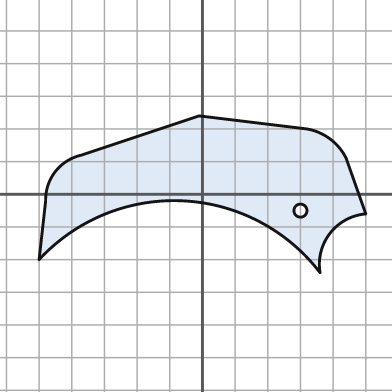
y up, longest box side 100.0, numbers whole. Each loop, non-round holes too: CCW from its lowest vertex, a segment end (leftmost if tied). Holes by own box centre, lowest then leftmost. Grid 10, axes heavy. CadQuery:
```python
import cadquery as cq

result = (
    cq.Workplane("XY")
    .moveTo(36.0, -24.0)
    .threePointArc((39.0, -12.0), (50.0, -6.0))
    .lineTo(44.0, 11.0)
    .threePointArc((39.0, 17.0), (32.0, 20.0))
    .lineTo(-1.0, 24.0)
    .lineTo(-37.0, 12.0)
    .threePointArc((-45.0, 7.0), (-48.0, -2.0))
    .lineTo(-50.0, -20.0)
    .threePointArc((-6.0, -2.0), (36.0, -24.0))
    .close()
    .moveTo(30.0, -5.0)
    .circle(2.0)
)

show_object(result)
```